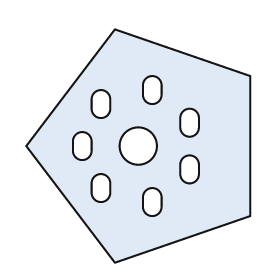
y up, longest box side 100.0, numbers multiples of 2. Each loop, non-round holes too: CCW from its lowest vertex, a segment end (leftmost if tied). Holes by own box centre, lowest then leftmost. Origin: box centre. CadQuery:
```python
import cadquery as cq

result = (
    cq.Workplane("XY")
    .moveTo(-10.0, -50.0)
    .lineTo(48.0, -30.0)
    .lineTo(48.0, 30.0)
    .lineTo(-10.0, 50.0)
    .lineTo(-48.0, 0.0)
    .close()
    .moveTo(2.0, -26.0)
    .threePointArc((6.0, -30.0), (10.0, -26.0))
    .lineTo(10.0, -22.0)
    .threePointArc((6.0, -18.0), (2.0, -22.0))
    .close()
    .moveTo(-20.0, -20.0)
    .threePointArc((-16.0, -24.0), (-12.0, -20.0))
    .lineTo(-12.0, -16.0)
    .threePointArc((-16.0, -12.0), (-20.0, -16.0))
    .close()
    .moveTo(18.0, -12.0)
    .threePointArc((22.0, -16.0), (26.0, -12.0))
    .lineTo(26.0, -8.0)
    .threePointArc((22.0, -4.0), (18.0, -8.0))
    .close()
    .moveTo(-28.0, -2.0)
    .threePointArc((-24.0, -6.0), (-20.0, -2.0))
    .lineTo(-20.0, 2.0)
    .threePointArc((-24.0, 6.0), (-28.0, 2.0))
    .close()
    .moveTo(0.0, 0.0)
    .circle(8.0)
    .moveTo(18.0, 8.0)
    .threePointArc((22.0, 4.0), (26.0, 8.0))
    .lineTo(26.0, 12.0)
    .threePointArc((22.0, 16.0), (18.0, 12.0))
    .close()
    .moveTo(-20.0, 16.0)
    .threePointArc((-16.0, 12.0), (-12.0, 16.0))
    .lineTo(-12.0, 20.0)
    .threePointArc((-16.0, 24.0), (-20.0, 20.0))
    .close()
    .moveTo(2.0, 22.0)
    .threePointArc((6.0, 18.0), (10.0, 22.0))
    .lineTo(10.0, 26.0)
    .threePointArc((6.0, 30.0), (2.0, 26.0))
    .close()
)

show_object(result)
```